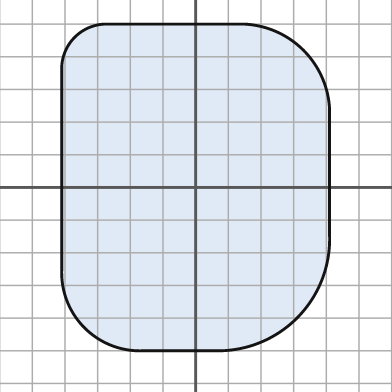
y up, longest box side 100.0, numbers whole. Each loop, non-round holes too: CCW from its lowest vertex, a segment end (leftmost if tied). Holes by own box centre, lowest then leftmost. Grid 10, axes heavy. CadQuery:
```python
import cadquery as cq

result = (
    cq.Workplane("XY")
    .moveTo(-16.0, -50.0)
    .lineTo(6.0, -50.0)
    .threePointArc((31.0, -40.0), (41.0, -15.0))
    .lineTo(41.0, 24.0)
    .threePointArc((33.0, 42.0), (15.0, 50.0))
    .lineTo(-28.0, 50.0)
    .threePointArc((-37.0, 46.0), (-41.0, 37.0))
    .lineTo(-41.0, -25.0)
    .threePointArc((-34.0, -43.0), (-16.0, -50.0))
    .close()
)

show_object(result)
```